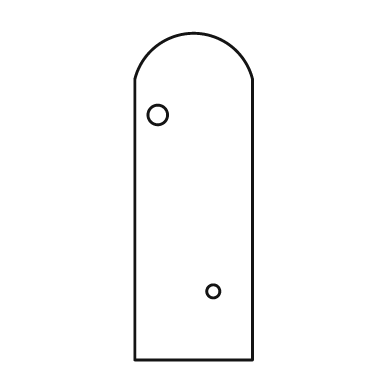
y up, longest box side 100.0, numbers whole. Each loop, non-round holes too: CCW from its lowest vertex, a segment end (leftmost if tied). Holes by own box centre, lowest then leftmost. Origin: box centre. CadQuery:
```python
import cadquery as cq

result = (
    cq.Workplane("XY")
    .moveTo(-18.0, -50.0)
    .lineTo(18.0, -50.0)
    .lineTo(18.0, 36.0)
    .threePointArc((0.0, 50.0), (-18.0, 36.0))
    .close()
    .moveTo(6.0, -29.0)
    .circle(2.0)
    .moveTo(-11.0, 25.0)
    .circle(3.0)
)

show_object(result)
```